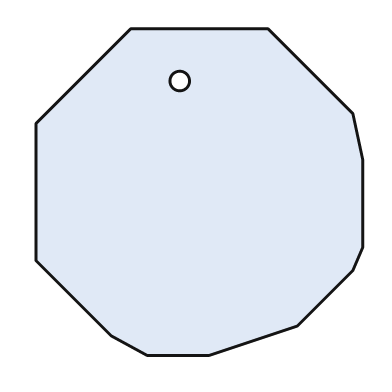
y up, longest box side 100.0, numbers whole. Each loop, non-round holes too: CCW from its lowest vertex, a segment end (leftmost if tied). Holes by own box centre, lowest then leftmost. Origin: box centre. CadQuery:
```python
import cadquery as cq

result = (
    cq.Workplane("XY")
    .moveTo(-16.0, -50.0)
    .lineTo(3.0, -50.0)
    .lineTo(30.0, -41.0)
    .lineTo(47.0, -24.0)
    .lineTo(50.0, -17.0)
    .lineTo(50.0, 10.0)
    .lineTo(47.0, 24.0)
    .lineTo(21.0, 50.0)
    .lineTo(-21.0, 50.0)
    .lineTo(-50.0, 21.0)
    .lineTo(-50.0, -21.0)
    .lineTo(-27.0, -44.0)
    .close()
    .moveTo(-6.0, 34.0)
    .circle(3.0)
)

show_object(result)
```